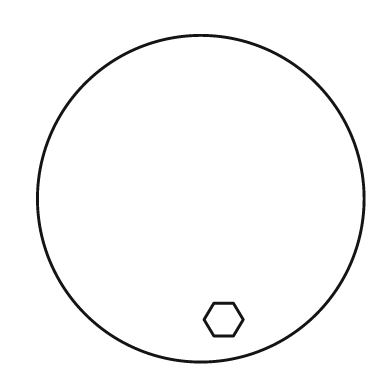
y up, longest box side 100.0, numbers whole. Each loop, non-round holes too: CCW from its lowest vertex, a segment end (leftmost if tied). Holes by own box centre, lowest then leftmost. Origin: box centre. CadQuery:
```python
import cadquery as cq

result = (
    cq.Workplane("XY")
    .moveTo(0.0, 0.0)
    .circle(50.0)
    .moveTo(4.0, -42.0)
    .lineTo(10.0, -42.0)
    .lineTo(13.0, -37.0)
    .lineTo(10.0, -32.0)
    .lineTo(4.0, -32.0)
    .lineTo(1.0, -37.0)
    .close()
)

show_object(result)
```